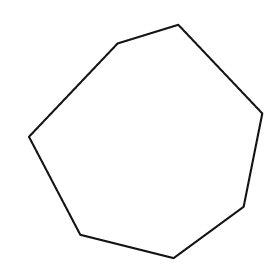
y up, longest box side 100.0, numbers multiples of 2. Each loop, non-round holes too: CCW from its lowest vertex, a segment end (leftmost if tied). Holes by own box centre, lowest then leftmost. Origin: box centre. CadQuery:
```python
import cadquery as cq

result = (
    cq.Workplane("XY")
    .moveTo(12.0, -50.0)
    .lineTo(42.0, -28.0)
    .lineTo(50.0, 12.0)
    .lineTo(14.0, 50.0)
    .lineTo(-12.0, 42.0)
    .lineTo(-50.0, 2.0)
    .lineTo(-28.0, -40.0)
    .close()
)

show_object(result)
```